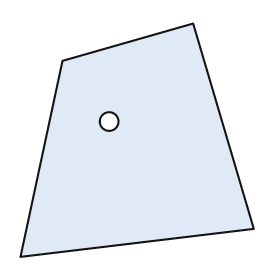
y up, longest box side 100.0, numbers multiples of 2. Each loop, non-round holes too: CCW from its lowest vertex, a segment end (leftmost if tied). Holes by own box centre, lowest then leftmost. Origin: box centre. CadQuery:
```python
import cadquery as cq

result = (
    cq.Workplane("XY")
    .moveTo(-50.0, -50.0)
    .lineTo(50.0, -38.0)
    .lineTo(24.0, 50.0)
    .lineTo(-32.0, 34.0)
    .close()
    .moveTo(-12.0, 8.0)
    .circle(4.0)
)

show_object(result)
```